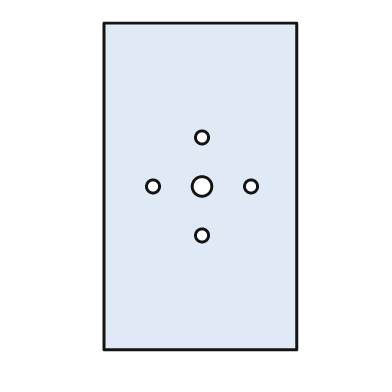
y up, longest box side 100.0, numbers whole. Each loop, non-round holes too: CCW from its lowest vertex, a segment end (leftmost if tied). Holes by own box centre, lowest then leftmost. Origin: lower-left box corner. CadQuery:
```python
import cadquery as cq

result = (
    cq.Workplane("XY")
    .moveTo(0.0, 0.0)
    .lineTo(59.0, 0.0)
    .lineTo(59.0, 100.0)
    .lineTo(0.0, 100.0)
    .close()
    .moveTo(30.0, 35.0)
    .circle(2.0)
    .moveTo(15.0, 50.0)
    .circle(2.0)
    .moveTo(30.0, 50.0)
    .circle(3.0)
    .moveTo(45.0, 50.0)
    .circle(2.0)
    .moveTo(30.0, 65.0)
    .circle(2.0)
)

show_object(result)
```